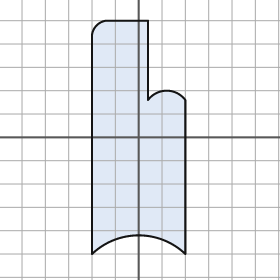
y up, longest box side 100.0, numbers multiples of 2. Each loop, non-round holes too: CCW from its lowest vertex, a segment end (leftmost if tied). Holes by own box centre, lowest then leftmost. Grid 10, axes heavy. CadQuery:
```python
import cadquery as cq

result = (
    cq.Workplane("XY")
    .moveTo(-20.0, -50.0)
    .threePointArc((0.0, -42.0), (20.0, -50.0))
    .lineTo(20.0, 16.0)
    .threePointArc((12.0, 20.0), (4.0, 16.0))
    .lineTo(4.0, 50.0)
    .lineTo(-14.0, 50.0)
    .threePointArc((-18.0, 48.0), (-20.0, 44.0))
    .close()
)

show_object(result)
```